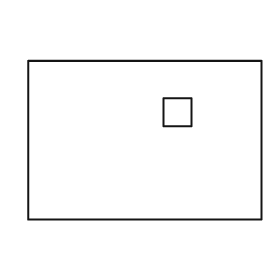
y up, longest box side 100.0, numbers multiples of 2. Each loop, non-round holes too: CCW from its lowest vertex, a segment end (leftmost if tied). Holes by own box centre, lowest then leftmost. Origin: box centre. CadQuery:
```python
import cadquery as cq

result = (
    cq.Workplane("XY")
    .moveTo(-50.0, -34.0)
    .lineTo(50.0, -34.0)
    .lineTo(50.0, 34.0)
    .lineTo(-50.0, 34.0)
    .close()
    .moveTo(8.0, 6.0)
    .lineTo(20.0, 6.0)
    .lineTo(20.0, 18.0)
    .lineTo(8.0, 18.0)
    .close()
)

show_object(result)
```